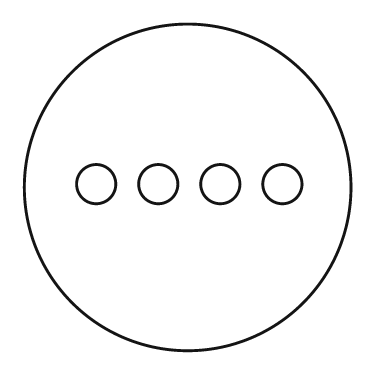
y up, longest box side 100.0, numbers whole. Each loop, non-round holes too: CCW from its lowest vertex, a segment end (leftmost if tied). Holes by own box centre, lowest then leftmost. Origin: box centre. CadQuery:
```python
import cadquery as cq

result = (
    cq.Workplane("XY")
    .moveTo(0.0, 0.0)
    .circle(50.0)
    .moveTo(-28.0, 1.0)
    .circle(6.0)
    .moveTo(-9.0, 1.0)
    .circle(6.0)
    .moveTo(10.0, 1.0)
    .circle(6.0)
    .moveTo(29.0, 1.0)
    .circle(6.0)
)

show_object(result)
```